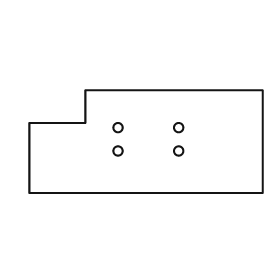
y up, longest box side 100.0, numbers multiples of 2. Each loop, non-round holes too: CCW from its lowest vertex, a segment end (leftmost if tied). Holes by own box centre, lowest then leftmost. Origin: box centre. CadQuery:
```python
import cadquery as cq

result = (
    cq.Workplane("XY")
    .moveTo(-50.0, -22.0)
    .lineTo(50.0, -22.0)
    .lineTo(50.0, 22.0)
    .lineTo(-26.0, 22.0)
    .lineTo(-26.0, 8.0)
    .lineTo(-50.0, 8.0)
    .close()
    .moveTo(-12.0, -4.0)
    .circle(2.0)
    .moveTo(14.0, -4.0)
    .circle(2.0)
    .moveTo(-12.0, 6.0)
    .circle(2.0)
    .moveTo(14.0, 6.0)
    .circle(2.0)
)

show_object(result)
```